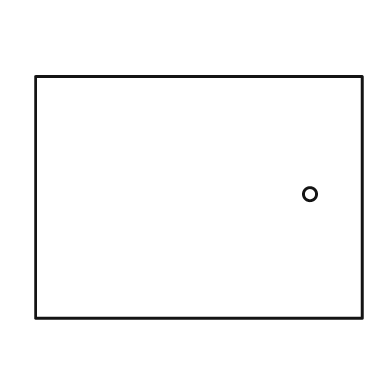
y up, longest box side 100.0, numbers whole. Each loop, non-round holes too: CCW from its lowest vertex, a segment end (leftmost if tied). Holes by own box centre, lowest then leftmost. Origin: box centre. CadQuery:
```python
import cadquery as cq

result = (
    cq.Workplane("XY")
    .moveTo(-50.0, -37.0)
    .lineTo(50.0, -37.0)
    .lineTo(50.0, 37.0)
    .lineTo(-50.0, 37.0)
    .close()
    .moveTo(34.0, 1.0)
    .circle(2.0)
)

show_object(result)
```